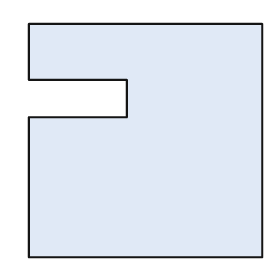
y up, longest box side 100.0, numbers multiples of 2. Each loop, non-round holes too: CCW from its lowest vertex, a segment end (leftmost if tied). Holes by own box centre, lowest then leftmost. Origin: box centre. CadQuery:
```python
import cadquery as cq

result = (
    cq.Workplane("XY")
    .moveTo(-50.0, -50.0)
    .lineTo(50.0, -50.0)
    .lineTo(50.0, 50.0)
    .lineTo(-50.0, 50.0)
    .lineTo(-50.0, 26.0)
    .lineTo(-8.0, 26.0)
    .lineTo(-8.0, 10.0)
    .lineTo(-50.0, 10.0)
    .close()
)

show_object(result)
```